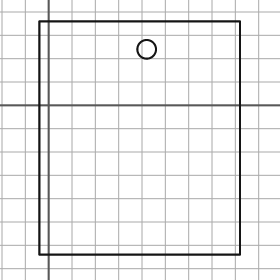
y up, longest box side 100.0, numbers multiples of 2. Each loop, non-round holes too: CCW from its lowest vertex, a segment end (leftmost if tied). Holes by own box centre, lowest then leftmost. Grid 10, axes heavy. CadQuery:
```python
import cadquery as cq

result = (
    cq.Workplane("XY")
    .moveTo(-4.0, -64.0)
    .lineTo(82.0, -64.0)
    .lineTo(82.0, 36.0)
    .lineTo(-4.0, 36.0)
    .close()
    .moveTo(42.0, 24.0)
    .circle(4.0)
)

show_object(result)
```